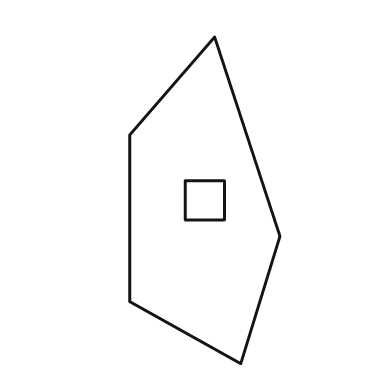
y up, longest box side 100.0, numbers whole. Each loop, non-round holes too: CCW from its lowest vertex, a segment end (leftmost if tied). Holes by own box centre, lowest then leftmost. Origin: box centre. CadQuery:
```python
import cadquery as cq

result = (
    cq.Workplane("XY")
    .moveTo(11.0, -50.0)
    .lineTo(23.0, -11.0)
    .lineTo(3.0, 50.0)
    .lineTo(-23.0, 20.0)
    .lineTo(-23.0, -31.0)
    .close()
    .moveTo(-6.0, -6.0)
    .lineTo(6.0, -6.0)
    .lineTo(6.0, 6.0)
    .lineTo(-6.0, 6.0)
    .close()
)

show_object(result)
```